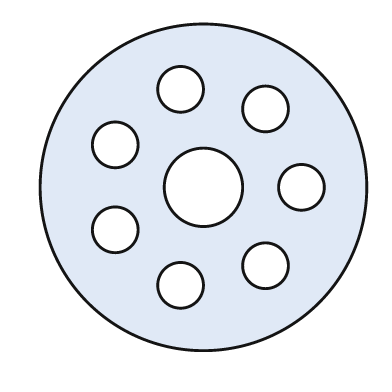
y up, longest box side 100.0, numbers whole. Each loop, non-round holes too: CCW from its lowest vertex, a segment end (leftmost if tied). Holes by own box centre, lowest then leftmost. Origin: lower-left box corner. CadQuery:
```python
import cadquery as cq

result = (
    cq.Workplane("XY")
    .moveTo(50.0, 50.0)
    .circle(50.0)
    .moveTo(43.0, 20.0)
    .circle(7.0)
    .moveTo(69.0, 26.0)
    .circle(7.0)
    .moveTo(23.0, 37.0)
    .circle(7.0)
    .moveTo(50.0, 50.0)
    .circle(12.0)
    .moveTo(80.0, 50.0)
    .circle(7.0)
    .moveTo(23.0, 63.0)
    .circle(7.0)
    .moveTo(69.0, 74.0)
    .circle(7.0)
    .moveTo(43.0, 80.0)
    .circle(7.0)
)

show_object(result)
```